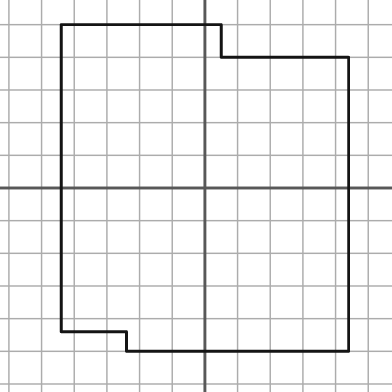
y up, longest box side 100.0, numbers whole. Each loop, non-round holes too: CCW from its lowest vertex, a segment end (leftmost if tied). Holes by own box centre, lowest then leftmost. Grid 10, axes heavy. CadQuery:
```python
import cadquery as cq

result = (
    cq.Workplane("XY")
    .moveTo(-24.0, -50.0)
    .lineTo(44.0, -50.0)
    .lineTo(44.0, 40.0)
    .lineTo(5.0, 40.0)
    .lineTo(5.0, 50.0)
    .lineTo(-44.0, 50.0)
    .lineTo(-44.0, -44.0)
    .lineTo(-24.0, -44.0)
    .close()
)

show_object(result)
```